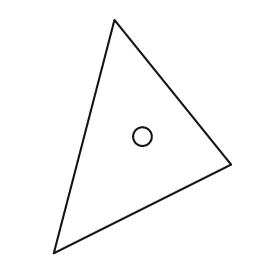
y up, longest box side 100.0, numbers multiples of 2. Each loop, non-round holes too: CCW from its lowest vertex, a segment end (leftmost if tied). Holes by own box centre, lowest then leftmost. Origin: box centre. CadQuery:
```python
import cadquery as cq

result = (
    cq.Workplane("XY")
    .moveTo(-38.0, -50.0)
    .lineTo(38.0, -12.0)
    .lineTo(-12.0, 50.0)
    .close()
    .moveTo(0.0, 0.0)
    .circle(4.0)
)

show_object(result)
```